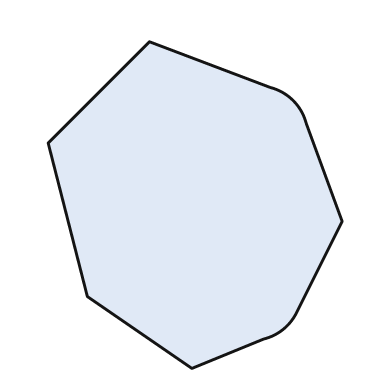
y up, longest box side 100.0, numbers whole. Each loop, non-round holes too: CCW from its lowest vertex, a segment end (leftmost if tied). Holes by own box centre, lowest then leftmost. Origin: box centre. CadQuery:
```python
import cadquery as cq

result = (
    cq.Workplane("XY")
    .moveTo(-1.0, -50.0)
    .lineTo(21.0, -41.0)
    .threePointArc((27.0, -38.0), (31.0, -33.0))
    .lineTo(45.0, -5.0)
    .lineTo(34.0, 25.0)
    .threePointArc((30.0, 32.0), (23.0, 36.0))
    .lineTo(-14.0, 50.0)
    .lineTo(-45.0, 19.0)
    .lineTo(-33.0, -28.0)
    .close()
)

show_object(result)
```